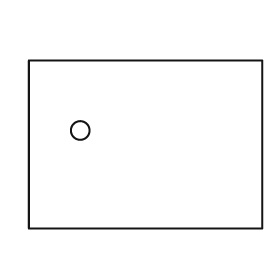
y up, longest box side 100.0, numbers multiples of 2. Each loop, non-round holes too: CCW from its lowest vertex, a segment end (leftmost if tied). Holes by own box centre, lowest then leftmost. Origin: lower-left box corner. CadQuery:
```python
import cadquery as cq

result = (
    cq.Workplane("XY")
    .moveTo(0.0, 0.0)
    .lineTo(100.0, 0.0)
    .lineTo(100.0, 72.0)
    .lineTo(0.0, 72.0)
    .close()
    .moveTo(22.0, 42.0)
    .circle(4.0)
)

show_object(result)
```